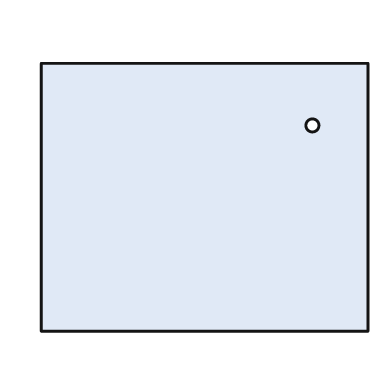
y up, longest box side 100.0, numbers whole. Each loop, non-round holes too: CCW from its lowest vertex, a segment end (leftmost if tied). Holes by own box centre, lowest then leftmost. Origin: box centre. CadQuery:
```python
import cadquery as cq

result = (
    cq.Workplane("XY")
    .moveTo(-50.0, -41.0)
    .lineTo(50.0, -41.0)
    .lineTo(50.0, 41.0)
    .lineTo(-50.0, 41.0)
    .close()
    .moveTo(33.0, 22.0)
    .circle(2.0)
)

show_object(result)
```